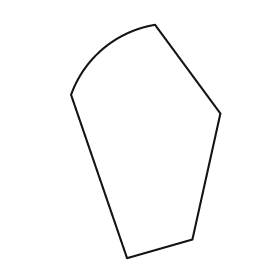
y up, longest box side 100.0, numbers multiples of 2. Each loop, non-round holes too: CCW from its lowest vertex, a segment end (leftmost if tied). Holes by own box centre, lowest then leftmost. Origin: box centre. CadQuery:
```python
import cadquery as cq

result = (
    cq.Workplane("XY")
    .moveTo(-8.0, -50.0)
    .lineTo(20.0, -42.0)
    .lineTo(32.0, 12.0)
    .lineTo(4.0, 50.0)
    .threePointArc((-18.0, 40.0), (-32.0, 20.0))
    .close()
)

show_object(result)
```